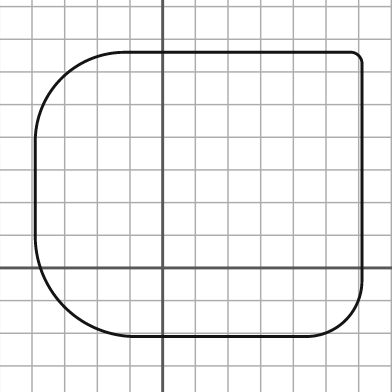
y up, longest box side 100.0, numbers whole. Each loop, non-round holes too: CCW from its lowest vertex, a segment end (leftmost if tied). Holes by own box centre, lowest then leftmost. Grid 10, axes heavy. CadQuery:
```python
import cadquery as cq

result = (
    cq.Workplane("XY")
    .moveTo(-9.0, -21.0)
    .lineTo(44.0, -21.0)
    .threePointArc((56.0, -16.0), (61.0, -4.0))
    .lineTo(61.0, 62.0)
    .threePointArc((60.0, 65.0), (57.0, 66.0))
    .lineTo(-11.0, 66.0)
    .threePointArc((-31.0, 58.0), (-39.0, 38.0))
    .lineTo(-39.0, 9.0)
    .threePointArc((-30.0, -12.0), (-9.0, -21.0))
    .close()
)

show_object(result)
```